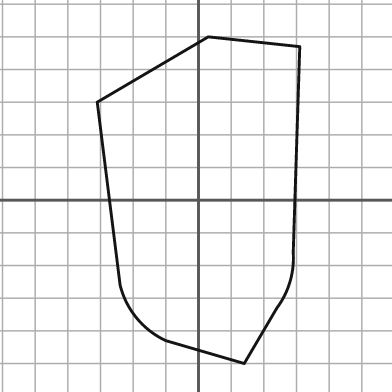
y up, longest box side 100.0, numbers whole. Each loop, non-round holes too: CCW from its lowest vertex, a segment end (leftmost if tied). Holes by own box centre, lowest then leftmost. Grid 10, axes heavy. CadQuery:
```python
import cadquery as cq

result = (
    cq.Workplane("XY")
    .moveTo(14.0, -50.0)
    .lineTo(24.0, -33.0)
    .threePointArc((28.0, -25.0), (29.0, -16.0))
    .lineTo(31.0, 47.0)
    .lineTo(3.0, 50.0)
    .lineTo(-31.0, 30.0)
    .lineTo(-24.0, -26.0)
    .threePointArc((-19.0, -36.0), (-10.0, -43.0))
    .close()
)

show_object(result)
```